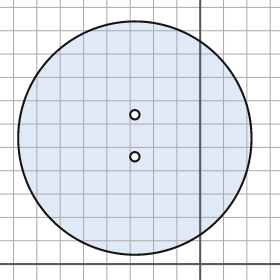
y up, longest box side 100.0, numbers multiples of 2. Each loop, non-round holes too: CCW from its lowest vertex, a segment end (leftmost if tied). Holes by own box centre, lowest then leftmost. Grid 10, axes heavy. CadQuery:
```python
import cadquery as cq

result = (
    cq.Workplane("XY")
    .moveTo(-28.0, 54.0)
    .circle(50.0)
    .moveTo(-28.0, 46.0)
    .circle(2.0)
    .moveTo(-28.0, 64.0)
    .circle(2.0)
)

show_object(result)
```